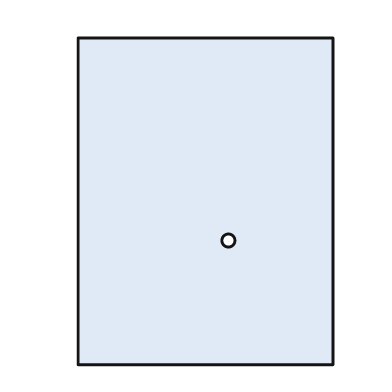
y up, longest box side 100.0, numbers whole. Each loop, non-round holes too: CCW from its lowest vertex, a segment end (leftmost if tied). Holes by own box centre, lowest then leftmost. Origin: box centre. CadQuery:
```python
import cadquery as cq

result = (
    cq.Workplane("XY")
    .moveTo(-39.0, -50.0)
    .lineTo(39.0, -50.0)
    .lineTo(39.0, 50.0)
    .lineTo(-39.0, 50.0)
    .close()
    .moveTo(7.0, -12.0)
    .circle(2.0)
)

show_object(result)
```